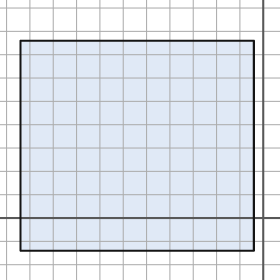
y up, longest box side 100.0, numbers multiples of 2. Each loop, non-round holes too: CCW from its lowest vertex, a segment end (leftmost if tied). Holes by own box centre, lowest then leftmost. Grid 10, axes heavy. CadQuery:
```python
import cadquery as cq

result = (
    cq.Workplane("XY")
    .moveTo(-104.0, -14.0)
    .lineTo(-4.0, -14.0)
    .lineTo(-4.0, 76.0)
    .lineTo(-104.0, 76.0)
    .close()
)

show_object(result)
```